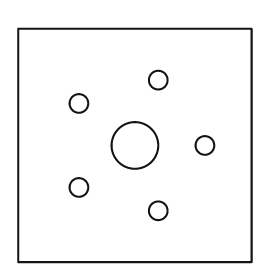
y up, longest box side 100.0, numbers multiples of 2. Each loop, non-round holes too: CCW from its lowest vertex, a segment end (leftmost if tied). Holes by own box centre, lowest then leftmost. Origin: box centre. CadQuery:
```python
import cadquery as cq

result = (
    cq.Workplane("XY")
    .moveTo(-50.0, -50.0)
    .lineTo(50.0, -50.0)
    .lineTo(50.0, 50.0)
    .lineTo(-50.0, 50.0)
    .close()
    .moveTo(10.0, -28.0)
    .circle(4.0)
    .moveTo(-24.0, -18.0)
    .circle(4.0)
    .moveTo(0.0, 0.0)
    .circle(10.0)
    .moveTo(30.0, 0.0)
    .circle(4.0)
    .moveTo(-24.0, 18.0)
    .circle(4.0)
    .moveTo(10.0, 28.0)
    .circle(4.0)
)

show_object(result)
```